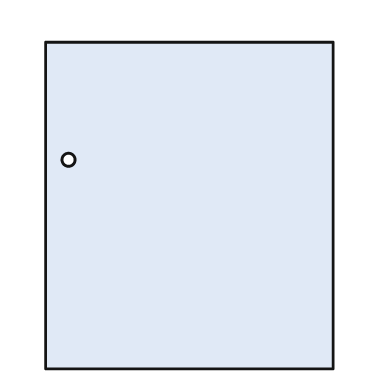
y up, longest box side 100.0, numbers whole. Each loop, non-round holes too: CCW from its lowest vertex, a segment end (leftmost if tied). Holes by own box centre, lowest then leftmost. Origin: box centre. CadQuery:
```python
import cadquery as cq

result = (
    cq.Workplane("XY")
    .moveTo(-44.0, -50.0)
    .lineTo(44.0, -50.0)
    .lineTo(44.0, 50.0)
    .lineTo(-44.0, 50.0)
    .close()
    .moveTo(-37.0, 14.0)
    .circle(2.0)
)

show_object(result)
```